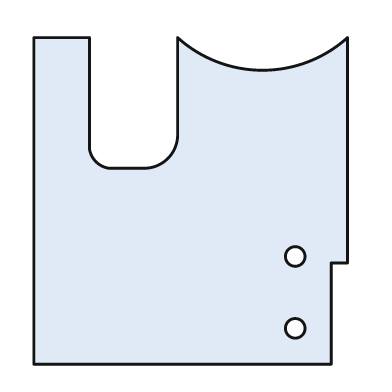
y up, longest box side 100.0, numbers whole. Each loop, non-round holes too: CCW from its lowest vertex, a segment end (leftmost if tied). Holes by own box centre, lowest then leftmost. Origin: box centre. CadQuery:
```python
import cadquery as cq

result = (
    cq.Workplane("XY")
    .moveTo(-48.0, -50.0)
    .lineTo(43.0, -50.0)
    .lineTo(43.0, -19.0)
    .lineTo(48.0, -19.0)
    .lineTo(48.0, 50.0)
    .threePointArc((22.0, 40.0), (-4.0, 50.0))
    .lineTo(-4.0, 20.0)
    .threePointArc((-7.0, 13.0), (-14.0, 10.0))
    .lineTo(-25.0, 10.0)
    .threePointArc((-29.0, 12.0), (-31.0, 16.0))
    .lineTo(-31.0, 50.0)
    .lineTo(-48.0, 50.0)
    .close()
    .moveTo(32.0, -39.0)
    .circle(3.0)
    .moveTo(32.0, -17.0)
    .circle(3.0)
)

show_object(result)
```